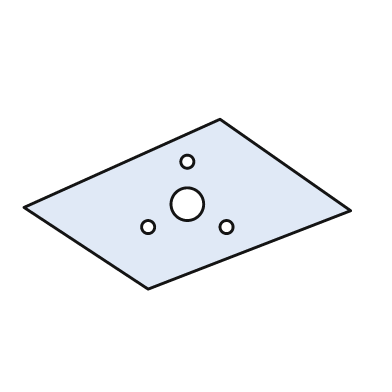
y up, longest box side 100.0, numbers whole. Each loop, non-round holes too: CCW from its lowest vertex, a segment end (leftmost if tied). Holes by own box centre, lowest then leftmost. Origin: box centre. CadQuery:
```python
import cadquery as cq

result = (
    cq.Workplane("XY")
    .moveTo(-12.0, -26.0)
    .lineTo(50.0, -2.0)
    .lineTo(10.0, 26.0)
    .lineTo(-50.0, -1.0)
    .close()
    .moveTo(-12.0, -7.0)
    .circle(2.0)
    .moveTo(12.0, -7.0)
    .circle(2.0)
    .moveTo(0.0, 0.0)
    .circle(5.0)
    .moveTo(0.0, 13.0)
    .circle(2.0)
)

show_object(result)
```